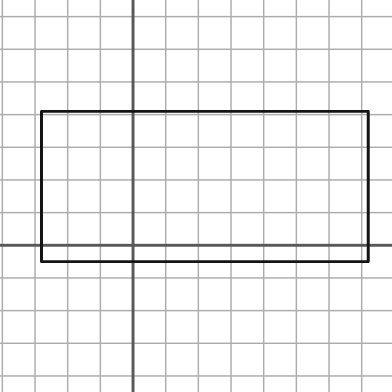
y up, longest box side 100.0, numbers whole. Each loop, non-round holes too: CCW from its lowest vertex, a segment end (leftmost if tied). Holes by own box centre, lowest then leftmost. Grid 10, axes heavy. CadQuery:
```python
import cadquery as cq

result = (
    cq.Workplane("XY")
    .moveTo(-28.0, -5.0)
    .lineTo(72.0, -5.0)
    .lineTo(72.0, 41.0)
    .lineTo(-28.0, 41.0)
    .close()
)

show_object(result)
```